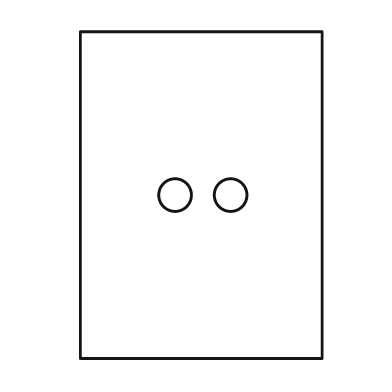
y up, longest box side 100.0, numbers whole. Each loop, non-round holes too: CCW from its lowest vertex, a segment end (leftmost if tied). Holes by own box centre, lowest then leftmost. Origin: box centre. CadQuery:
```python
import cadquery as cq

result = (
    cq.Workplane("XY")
    .moveTo(-37.0, -50.0)
    .lineTo(37.0, -50.0)
    .lineTo(37.0, 50.0)
    .lineTo(-37.0, 50.0)
    .close()
    .moveTo(-8.0, 0.0)
    .circle(5.0)
    .moveTo(9.0, 0.0)
    .circle(5.0)
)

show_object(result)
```